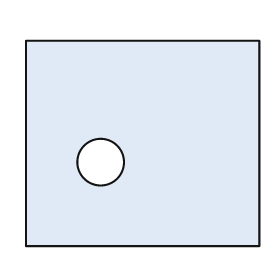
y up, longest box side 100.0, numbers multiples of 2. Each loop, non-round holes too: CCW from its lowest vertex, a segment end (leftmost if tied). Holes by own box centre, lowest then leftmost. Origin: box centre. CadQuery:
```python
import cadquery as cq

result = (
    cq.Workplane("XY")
    .moveTo(-50.0, -44.0)
    .lineTo(50.0, -44.0)
    .lineTo(50.0, 44.0)
    .lineTo(-50.0, 44.0)
    .close()
    .moveTo(-18.0, -8.0)
    .circle(10.0)
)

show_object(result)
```